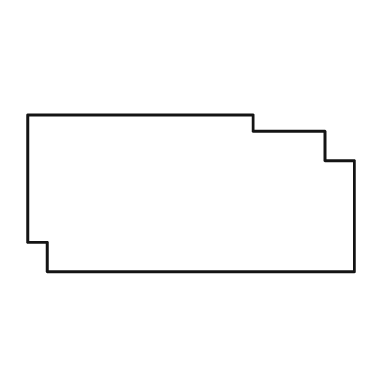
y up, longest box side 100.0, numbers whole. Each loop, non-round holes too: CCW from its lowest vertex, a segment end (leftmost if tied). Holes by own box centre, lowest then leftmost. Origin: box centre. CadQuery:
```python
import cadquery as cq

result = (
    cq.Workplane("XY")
    .moveTo(-44.0, -24.0)
    .lineTo(50.0, -24.0)
    .lineTo(50.0, 10.0)
    .lineTo(41.0, 10.0)
    .lineTo(41.0, 19.0)
    .lineTo(19.0, 19.0)
    .lineTo(19.0, 24.0)
    .lineTo(-50.0, 24.0)
    .lineTo(-50.0, -15.0)
    .lineTo(-44.0, -15.0)
    .close()
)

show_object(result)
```